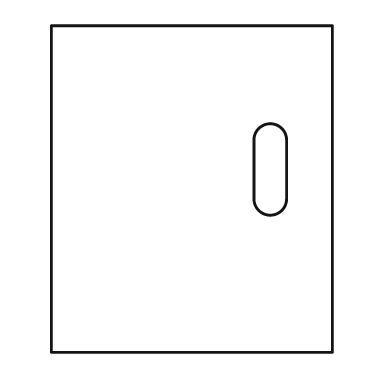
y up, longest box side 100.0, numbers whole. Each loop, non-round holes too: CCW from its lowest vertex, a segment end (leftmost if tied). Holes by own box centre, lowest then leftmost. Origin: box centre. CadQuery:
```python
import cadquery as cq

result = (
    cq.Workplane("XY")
    .moveTo(-43.0, -50.0)
    .lineTo(43.0, -50.0)
    .lineTo(43.0, 50.0)
    .lineTo(-43.0, 50.0)
    .close()
    .moveTo(19.0, -3.0)
    .threePointArc((24.0, -8.0), (29.0, -3.0))
    .lineTo(29.0, 15.0)
    .threePointArc((24.0, 20.0), (19.0, 15.0))
    .close()
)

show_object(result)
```